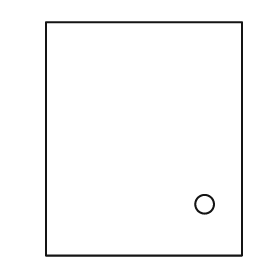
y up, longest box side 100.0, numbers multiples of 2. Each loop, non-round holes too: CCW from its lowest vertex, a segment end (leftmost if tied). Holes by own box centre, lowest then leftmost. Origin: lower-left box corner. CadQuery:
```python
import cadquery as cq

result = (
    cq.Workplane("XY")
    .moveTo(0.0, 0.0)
    .lineTo(84.0, 0.0)
    .lineTo(84.0, 100.0)
    .lineTo(0.0, 100.0)
    .close()
    .moveTo(68.0, 22.0)
    .circle(4.0)
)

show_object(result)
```